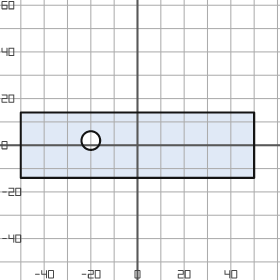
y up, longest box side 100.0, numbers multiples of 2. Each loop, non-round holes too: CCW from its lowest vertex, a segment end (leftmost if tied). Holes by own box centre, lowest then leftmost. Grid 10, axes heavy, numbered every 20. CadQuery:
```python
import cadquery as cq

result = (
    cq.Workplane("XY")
    .moveTo(-50.0, -14.0)
    .lineTo(50.0, -14.0)
    .lineTo(50.0, 14.0)
    .lineTo(-50.0, 14.0)
    .close()
    .moveTo(-20.0, 2.0)
    .circle(4.0)
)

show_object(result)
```